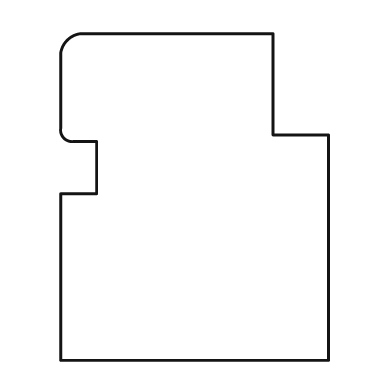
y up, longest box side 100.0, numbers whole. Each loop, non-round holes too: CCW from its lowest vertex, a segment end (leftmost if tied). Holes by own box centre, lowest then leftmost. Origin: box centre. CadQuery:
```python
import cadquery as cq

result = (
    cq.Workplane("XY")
    .moveTo(-41.0, -50.0)
    .lineTo(41.0, -50.0)
    .lineTo(41.0, 19.0)
    .lineTo(24.0, 19.0)
    .lineTo(24.0, 50.0)
    .lineTo(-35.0, 50.0)
    .threePointArc((-39.0, 48.0), (-41.0, 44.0))
    .lineTo(-41.0, 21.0)
    .threePointArc((-40.0, 18.0), (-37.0, 17.0))
    .lineTo(-30.0, 17.0)
    .lineTo(-30.0, 1.0)
    .lineTo(-41.0, 1.0)
    .close()
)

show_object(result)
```